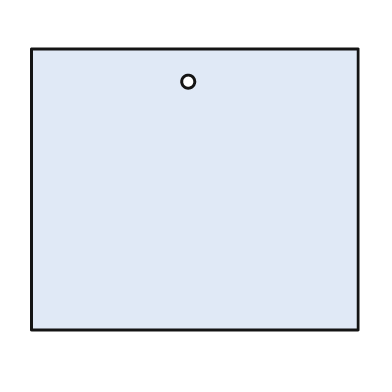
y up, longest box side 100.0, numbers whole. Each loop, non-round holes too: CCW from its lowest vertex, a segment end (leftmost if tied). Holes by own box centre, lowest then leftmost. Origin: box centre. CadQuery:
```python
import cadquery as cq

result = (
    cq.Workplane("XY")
    .moveTo(-50.0, -43.0)
    .lineTo(50.0, -43.0)
    .lineTo(50.0, 43.0)
    .lineTo(-50.0, 43.0)
    .close()
    .moveTo(-2.0, 33.0)
    .circle(2.0)
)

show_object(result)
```